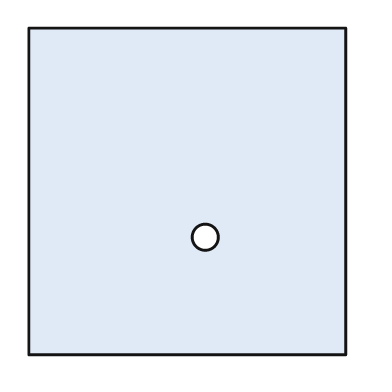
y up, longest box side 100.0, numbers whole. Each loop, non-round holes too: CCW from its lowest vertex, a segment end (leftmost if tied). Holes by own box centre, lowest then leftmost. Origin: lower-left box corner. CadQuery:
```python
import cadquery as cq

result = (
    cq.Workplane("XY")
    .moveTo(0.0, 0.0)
    .lineTo(97.0, 0.0)
    .lineTo(97.0, 100.0)
    .lineTo(0.0, 100.0)
    .close()
    .moveTo(54.0, 36.0)
    .circle(4.0)
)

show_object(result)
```